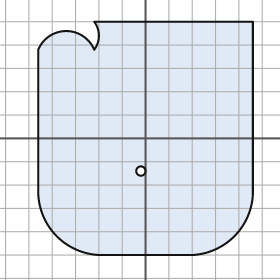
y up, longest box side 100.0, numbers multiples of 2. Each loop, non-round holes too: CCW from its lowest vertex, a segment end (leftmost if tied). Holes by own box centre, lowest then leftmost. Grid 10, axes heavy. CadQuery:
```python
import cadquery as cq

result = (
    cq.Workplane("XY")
    .moveTo(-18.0, -50.0)
    .lineTo(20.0, -50.0)
    .threePointArc((38.0, -42.0), (46.0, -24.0))
    .lineTo(46.0, 50.0)
    .lineTo(-22.0, 50.0)
    .threePointArc((-20.0, 44.0), (-22.0, 38.0))
    .threePointArc((-34.0, 46.0), (-46.0, 38.0))
    .lineTo(-46.0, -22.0)
    .threePointArc((-38.0, -42.0), (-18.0, -50.0))
    .close()
    .moveTo(-2.0, -14.0)
    .circle(2.0)
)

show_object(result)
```